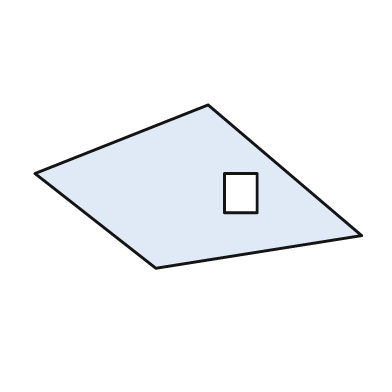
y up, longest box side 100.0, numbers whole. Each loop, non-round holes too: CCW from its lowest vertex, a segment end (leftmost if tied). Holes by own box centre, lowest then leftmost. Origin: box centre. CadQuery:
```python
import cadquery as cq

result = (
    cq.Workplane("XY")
    .moveTo(-13.0, -25.0)
    .lineTo(50.0, -15.0)
    .lineTo(3.0, 25.0)
    .lineTo(-50.0, 4.0)
    .close()
    .moveTo(8.0, -8.0)
    .lineTo(18.0, -8.0)
    .lineTo(18.0, 4.0)
    .lineTo(8.0, 4.0)
    .close()
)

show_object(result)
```